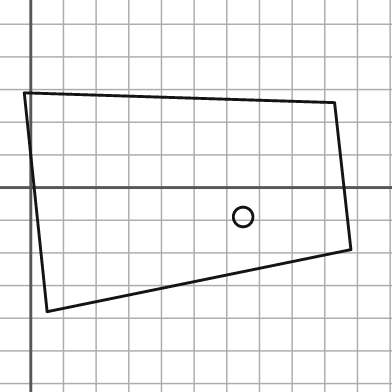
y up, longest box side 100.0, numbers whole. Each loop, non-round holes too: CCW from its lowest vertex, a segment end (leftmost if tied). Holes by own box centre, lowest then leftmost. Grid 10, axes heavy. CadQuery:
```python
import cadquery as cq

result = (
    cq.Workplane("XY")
    .moveTo(5.0, -38.0)
    .lineTo(98.0, -19.0)
    .lineTo(93.0, 26.0)
    .lineTo(-2.0, 29.0)
    .close()
    .moveTo(65.0, -9.0)
    .circle(3.0)
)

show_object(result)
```